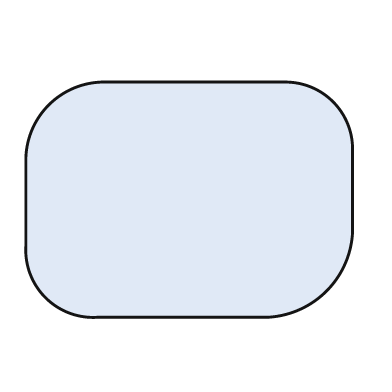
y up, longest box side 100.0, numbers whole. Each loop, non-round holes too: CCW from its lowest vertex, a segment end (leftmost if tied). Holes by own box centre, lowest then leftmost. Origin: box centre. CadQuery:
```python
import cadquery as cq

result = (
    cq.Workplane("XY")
    .moveTo(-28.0, -36.0)
    .lineTo(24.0, -36.0)
    .threePointArc((42.0, -28.0), (50.0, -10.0))
    .lineTo(50.0, 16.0)
    .threePointArc((44.0, 30.0), (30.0, 36.0))
    .lineTo(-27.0, 36.0)
    .threePointArc((-43.0, 29.0), (-50.0, 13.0))
    .lineTo(-50.0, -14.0)
    .threePointArc((-44.0, -30.0), (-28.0, -36.0))
    .close()
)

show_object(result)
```